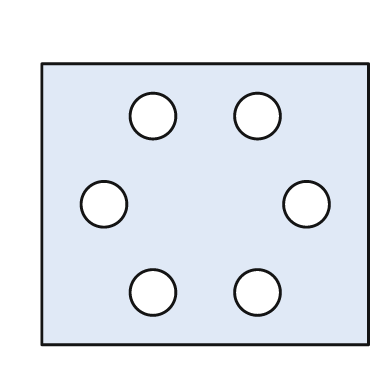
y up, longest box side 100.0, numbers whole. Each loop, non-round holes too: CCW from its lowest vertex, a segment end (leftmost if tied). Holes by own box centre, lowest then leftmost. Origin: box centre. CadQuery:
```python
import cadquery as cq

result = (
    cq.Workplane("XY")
    .moveTo(-50.0, -43.0)
    .lineTo(50.0, -43.0)
    .lineTo(50.0, 43.0)
    .lineTo(-50.0, 43.0)
    .close()
    .moveTo(-16.0, -27.0)
    .circle(7.0)
    .moveTo(16.0, -27.0)
    .circle(7.0)
    .moveTo(-31.0, 0.0)
    .circle(7.0)
    .moveTo(31.0, 0.0)
    .circle(7.0)
    .moveTo(-16.0, 27.0)
    .circle(7.0)
    .moveTo(16.0, 27.0)
    .circle(7.0)
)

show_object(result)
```